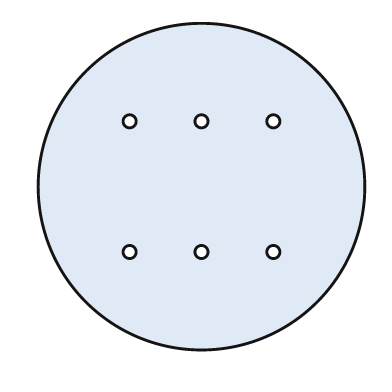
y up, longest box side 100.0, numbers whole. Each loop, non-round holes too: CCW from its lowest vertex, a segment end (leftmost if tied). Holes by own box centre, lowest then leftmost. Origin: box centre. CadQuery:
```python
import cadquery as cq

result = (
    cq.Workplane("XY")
    .moveTo(0.0, 0.0)
    .circle(50.0)
    .moveTo(-22.0, -20.0)
    .circle(2.0)
    .moveTo(0.0, -20.0)
    .circle(2.0)
    .moveTo(22.0, -20.0)
    .circle(2.0)
    .moveTo(-22.0, 20.0)
    .circle(2.0)
    .moveTo(0.0, 20.0)
    .circle(2.0)
    .moveTo(22.0, 20.0)
    .circle(2.0)
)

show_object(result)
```